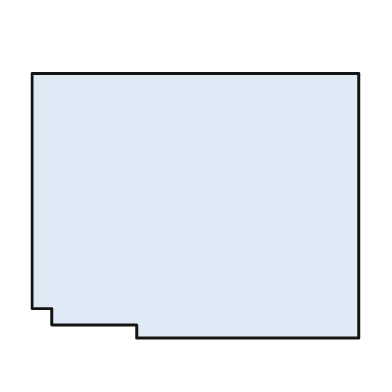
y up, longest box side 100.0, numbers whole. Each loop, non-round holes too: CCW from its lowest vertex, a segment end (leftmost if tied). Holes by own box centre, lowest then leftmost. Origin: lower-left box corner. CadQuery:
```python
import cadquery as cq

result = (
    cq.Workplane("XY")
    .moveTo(32.0, 0.0)
    .lineTo(100.0, 0.0)
    .lineTo(100.0, 81.0)
    .lineTo(0.0, 81.0)
    .lineTo(0.0, 9.0)
    .lineTo(6.0, 9.0)
    .lineTo(6.0, 4.0)
    .lineTo(32.0, 4.0)
    .close()
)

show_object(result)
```